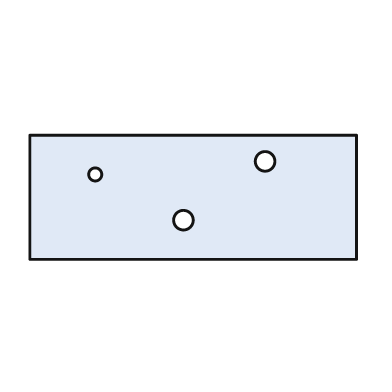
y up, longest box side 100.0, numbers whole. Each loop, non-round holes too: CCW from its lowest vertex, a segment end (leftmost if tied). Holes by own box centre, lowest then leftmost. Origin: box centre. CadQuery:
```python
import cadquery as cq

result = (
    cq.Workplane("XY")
    .moveTo(-50.0, -19.0)
    .lineTo(50.0, -19.0)
    .lineTo(50.0, 19.0)
    .lineTo(-50.0, 19.0)
    .close()
    .moveTo(-3.0, -7.0)
    .circle(3.0)
    .moveTo(-30.0, 7.0)
    .circle(2.0)
    .moveTo(22.0, 11.0)
    .circle(3.0)
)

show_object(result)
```